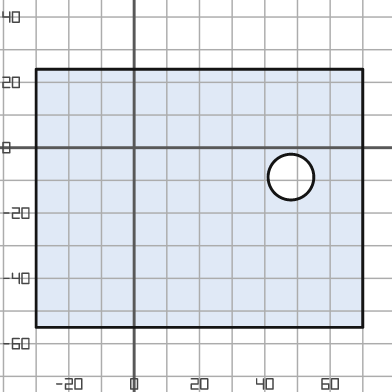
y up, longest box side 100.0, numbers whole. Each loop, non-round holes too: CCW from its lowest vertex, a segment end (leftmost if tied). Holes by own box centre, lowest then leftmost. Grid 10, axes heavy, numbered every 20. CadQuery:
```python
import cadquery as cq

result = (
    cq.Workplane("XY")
    .moveTo(-30.0, -55.0)
    .lineTo(70.0, -55.0)
    .lineTo(70.0, 24.0)
    .lineTo(-30.0, 24.0)
    .close()
    .moveTo(48.0, -9.0)
    .circle(7.0)
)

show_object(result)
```